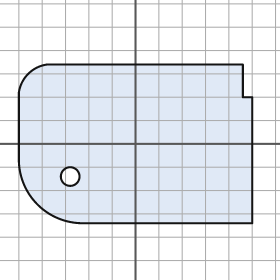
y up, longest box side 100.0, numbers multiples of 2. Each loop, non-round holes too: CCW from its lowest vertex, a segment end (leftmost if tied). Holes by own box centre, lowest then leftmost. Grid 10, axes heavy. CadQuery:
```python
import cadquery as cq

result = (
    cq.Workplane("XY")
    .moveTo(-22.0, -34.0)
    .lineTo(50.0, -34.0)
    .lineTo(50.0, 20.0)
    .lineTo(46.0, 20.0)
    .lineTo(46.0, 34.0)
    .lineTo(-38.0, 34.0)
    .threePointArc((-46.0, 30.0), (-50.0, 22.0))
    .lineTo(-50.0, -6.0)
    .threePointArc((-42.0, -26.0), (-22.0, -34.0))
    .close()
    .moveTo(-28.0, -14.0)
    .circle(4.0)
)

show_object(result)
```